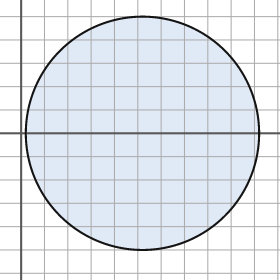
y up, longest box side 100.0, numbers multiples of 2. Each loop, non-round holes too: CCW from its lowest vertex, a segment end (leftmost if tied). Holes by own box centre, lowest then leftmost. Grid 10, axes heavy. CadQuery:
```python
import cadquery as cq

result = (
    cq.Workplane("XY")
    .moveTo(52.0, 0.0)
    .circle(50.0)
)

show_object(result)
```